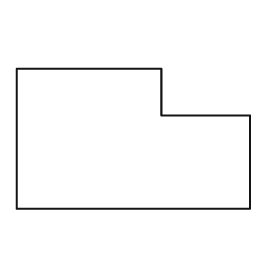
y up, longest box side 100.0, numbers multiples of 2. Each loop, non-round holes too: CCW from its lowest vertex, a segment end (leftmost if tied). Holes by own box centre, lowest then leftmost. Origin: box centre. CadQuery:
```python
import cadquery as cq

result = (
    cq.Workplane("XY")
    .moveTo(-50.0, -30.0)
    .lineTo(50.0, -30.0)
    .lineTo(50.0, 10.0)
    .lineTo(12.0, 10.0)
    .lineTo(12.0, 30.0)
    .lineTo(-50.0, 30.0)
    .close()
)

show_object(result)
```